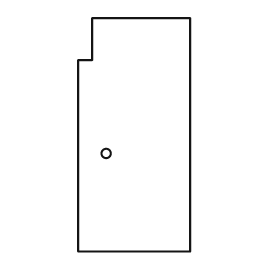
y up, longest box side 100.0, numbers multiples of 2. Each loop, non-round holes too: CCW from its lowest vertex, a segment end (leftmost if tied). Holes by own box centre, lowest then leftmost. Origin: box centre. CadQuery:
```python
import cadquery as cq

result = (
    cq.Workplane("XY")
    .moveTo(-24.0, -50.0)
    .lineTo(24.0, -50.0)
    .lineTo(24.0, 50.0)
    .lineTo(-18.0, 50.0)
    .lineTo(-18.0, 32.0)
    .lineTo(-24.0, 32.0)
    .close()
    .moveTo(-12.0, -8.0)
    .circle(2.0)
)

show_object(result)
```